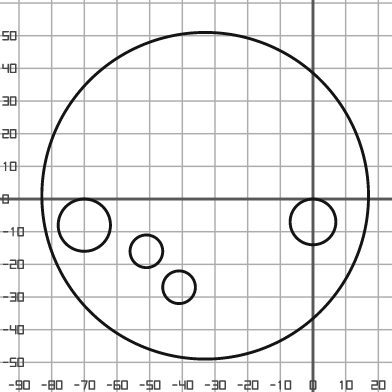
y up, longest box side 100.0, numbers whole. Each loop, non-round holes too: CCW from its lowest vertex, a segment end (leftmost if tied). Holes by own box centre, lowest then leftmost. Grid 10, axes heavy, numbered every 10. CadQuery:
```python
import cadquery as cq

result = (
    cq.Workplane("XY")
    .moveTo(-33.0, 1.0)
    .circle(50.0)
    .moveTo(-41.0, -27.0)
    .circle(5.0)
    .moveTo(-51.0, -16.0)
    .circle(5.0)
    .moveTo(-70.0, -8.0)
    .circle(8.0)
    .moveTo(0.0, -7.0)
    .circle(7.0)
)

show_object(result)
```